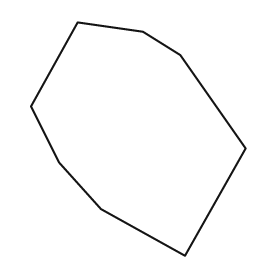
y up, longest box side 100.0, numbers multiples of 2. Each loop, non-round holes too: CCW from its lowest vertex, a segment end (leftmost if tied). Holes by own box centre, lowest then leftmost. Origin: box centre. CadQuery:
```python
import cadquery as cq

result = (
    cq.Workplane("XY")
    .moveTo(20.0, -50.0)
    .lineTo(46.0, -4.0)
    .lineTo(18.0, 36.0)
    .lineTo(2.0, 46.0)
    .lineTo(-26.0, 50.0)
    .lineTo(-46.0, 14.0)
    .lineTo(-34.0, -10.0)
    .lineTo(-16.0, -30.0)
    .close()
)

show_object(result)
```